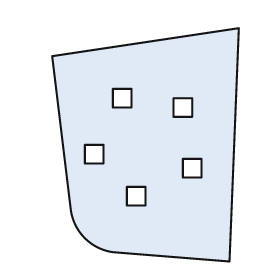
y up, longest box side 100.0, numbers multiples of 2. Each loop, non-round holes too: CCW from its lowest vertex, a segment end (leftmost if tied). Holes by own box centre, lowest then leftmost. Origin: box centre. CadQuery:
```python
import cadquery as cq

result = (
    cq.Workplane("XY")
    .moveTo(36.0, -50.0)
    .lineTo(40.0, 50.0)
    .lineTo(-40.0, 38.0)
    .lineTo(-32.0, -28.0)
    .threePointArc((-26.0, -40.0), (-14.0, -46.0))
    .close()
    .moveTo(-8.0, -26.0)
    .lineTo(0.0, -26.0)
    .lineTo(0.0, -18.0)
    .lineTo(-8.0, -18.0)
    .close()
    .moveTo(16.0, -14.0)
    .lineTo(24.0, -14.0)
    .lineTo(24.0, -6.0)
    .lineTo(16.0, -6.0)
    .close()
    .moveTo(-26.0, -8.0)
    .lineTo(-18.0, -8.0)
    .lineTo(-18.0, 0.0)
    .lineTo(-26.0, 0.0)
    .close()
    .moveTo(12.0, 12.0)
    .lineTo(20.0, 12.0)
    .lineTo(20.0, 20.0)
    .lineTo(12.0, 20.0)
    .close()
    .moveTo(-14.0, 16.0)
    .lineTo(-6.0, 16.0)
    .lineTo(-6.0, 24.0)
    .lineTo(-14.0, 24.0)
    .close()
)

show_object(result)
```